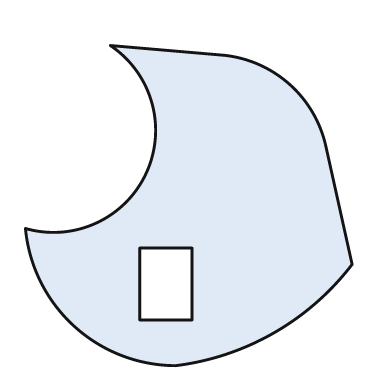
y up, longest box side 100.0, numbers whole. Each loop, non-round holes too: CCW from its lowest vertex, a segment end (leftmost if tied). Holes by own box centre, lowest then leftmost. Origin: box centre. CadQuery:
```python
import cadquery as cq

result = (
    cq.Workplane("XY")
    .moveTo(-4.0, -49.0)
    .threePointArc((26.0, -39.0), (50.0, -18.0))
    .lineTo(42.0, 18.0)
    .threePointArc((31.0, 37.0), (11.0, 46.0))
    .lineTo(-24.0, 49.0)
    .threePointArc((-13.0, 10.0), (-50.0, -7.0))
    .threePointArc((-35.0, -37.0), (-4.0, -49.0))
    .close()
    .moveTo(-15.0, -35.0)
    .lineTo(1.0, -35.0)
    .lineTo(1.0, -13.0)
    .lineTo(-15.0, -13.0)
    .close()
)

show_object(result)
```